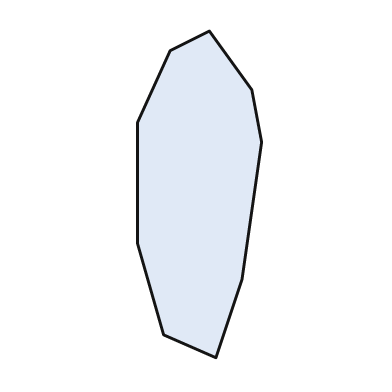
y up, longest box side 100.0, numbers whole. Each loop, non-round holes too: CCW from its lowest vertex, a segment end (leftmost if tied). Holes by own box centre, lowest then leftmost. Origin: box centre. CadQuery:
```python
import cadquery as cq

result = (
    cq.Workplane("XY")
    .moveTo(5.0, -50.0)
    .lineTo(13.0, -26.0)
    .lineTo(19.0, 16.0)
    .lineTo(16.0, 32.0)
    .lineTo(3.0, 50.0)
    .lineTo(-9.0, 44.0)
    .lineTo(-19.0, 22.0)
    .lineTo(-19.0, -15.0)
    .lineTo(-11.0, -43.0)
    .close()
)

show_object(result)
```